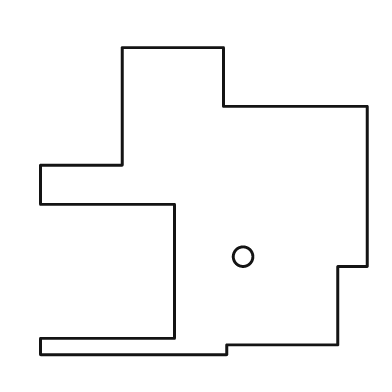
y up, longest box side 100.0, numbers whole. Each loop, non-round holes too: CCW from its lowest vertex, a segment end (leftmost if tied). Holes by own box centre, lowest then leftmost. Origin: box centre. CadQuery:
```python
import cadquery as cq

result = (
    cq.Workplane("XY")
    .moveTo(-50.0, -47.0)
    .lineTo(7.0, -47.0)
    .lineTo(7.0, -44.0)
    .lineTo(41.0, -44.0)
    .lineTo(41.0, -20.0)
    .lineTo(50.0, -20.0)
    .lineTo(50.0, 29.0)
    .lineTo(6.0, 29.0)
    .lineTo(6.0, 47.0)
    .lineTo(-25.0, 47.0)
    .lineTo(-25.0, 11.0)
    .lineTo(-50.0, 11.0)
    .lineTo(-50.0, -1.0)
    .lineTo(-9.0, -1.0)
    .lineTo(-9.0, -42.0)
    .lineTo(-50.0, -42.0)
    .close()
    .moveTo(12.0, -17.0)
    .circle(3.0)
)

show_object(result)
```